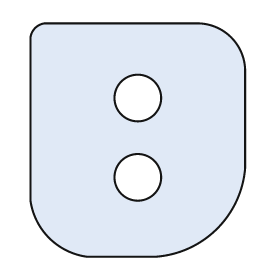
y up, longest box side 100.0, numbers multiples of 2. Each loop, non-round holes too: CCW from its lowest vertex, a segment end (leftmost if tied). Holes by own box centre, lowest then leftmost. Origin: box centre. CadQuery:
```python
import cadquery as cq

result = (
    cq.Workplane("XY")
    .moveTo(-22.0, -50.0)
    .lineTo(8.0, -50.0)
    .threePointArc((34.0, -38.0), (46.0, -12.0))
    .lineTo(46.0, 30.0)
    .threePointArc((40.0, 44.0), (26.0, 50.0))
    .lineTo(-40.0, 50.0)
    .threePointArc((-44.0, 48.0), (-46.0, 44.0))
    .lineTo(-46.0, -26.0)
    .threePointArc((-38.0, -42.0), (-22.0, -50.0))
    .close()
    .moveTo(0.0, -16.0)
    .circle(10.0)
    .moveTo(0.0, 18.0)
    .circle(10.0)
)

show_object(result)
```